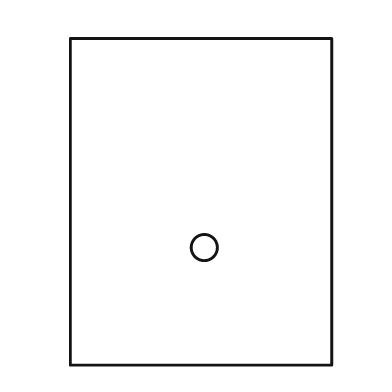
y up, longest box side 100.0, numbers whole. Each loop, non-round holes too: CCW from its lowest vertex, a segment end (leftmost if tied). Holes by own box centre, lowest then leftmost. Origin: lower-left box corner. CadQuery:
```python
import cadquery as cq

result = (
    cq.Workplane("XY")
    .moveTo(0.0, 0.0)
    .lineTo(80.0, 0.0)
    .lineTo(80.0, 100.0)
    .lineTo(0.0, 100.0)
    .close()
    .moveTo(41.0, 36.0)
    .circle(4.0)
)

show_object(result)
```